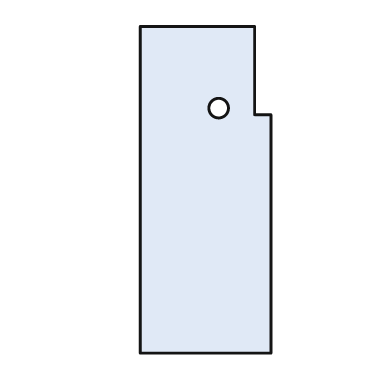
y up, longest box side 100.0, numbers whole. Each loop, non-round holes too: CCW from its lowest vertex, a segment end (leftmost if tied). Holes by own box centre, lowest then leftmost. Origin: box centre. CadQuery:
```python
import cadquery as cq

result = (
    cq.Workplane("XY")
    .moveTo(-20.0, -50.0)
    .lineTo(20.0, -50.0)
    .lineTo(20.0, 23.0)
    .lineTo(15.0, 23.0)
    .lineTo(15.0, 50.0)
    .lineTo(-20.0, 50.0)
    .close()
    .moveTo(4.0, 25.0)
    .circle(3.0)
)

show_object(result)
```